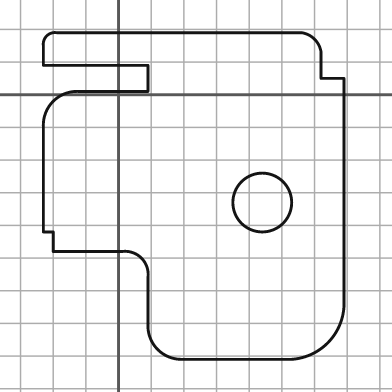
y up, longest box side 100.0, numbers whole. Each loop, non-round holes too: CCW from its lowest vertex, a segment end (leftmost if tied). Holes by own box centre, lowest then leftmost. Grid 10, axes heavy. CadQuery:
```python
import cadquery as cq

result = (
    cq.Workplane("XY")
    .moveTo(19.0, -81.0)
    .lineTo(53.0, -81.0)
    .threePointArc((64.0, -76.0), (69.0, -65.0))
    .lineTo(69.0, 5.0)
    .lineTo(62.0, 5.0)
    .lineTo(62.0, 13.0)
    .threePointArc((60.0, 17.0), (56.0, 19.0))
    .lineTo(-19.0, 19.0)
    .threePointArc((-22.0, 18.0), (-23.0, 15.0))
    .lineTo(-23.0, 9.0)
    .lineTo(9.0, 9.0)
    .lineTo(9.0, 1.0)
    .lineTo(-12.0, 1.0)
    .threePointArc((-20.0, -2.0), (-23.0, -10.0))
    .lineTo(-23.0, -42.0)
    .lineTo(-20.0, -42.0)
    .lineTo(-20.0, -48.0)
    .lineTo(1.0, -48.0)
    .threePointArc((7.0, -50.0), (9.0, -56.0))
    .lineTo(9.0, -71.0)
    .threePointArc((12.0, -78.0), (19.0, -81.0))
    .close()
    .moveTo(44.0, -33.0)
    .circle(9.0)
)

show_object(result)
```